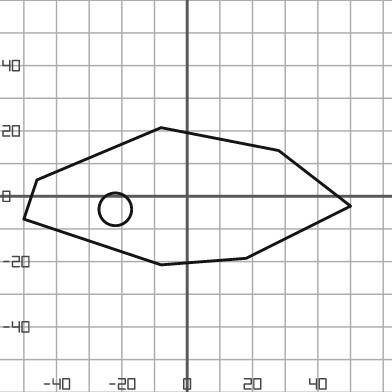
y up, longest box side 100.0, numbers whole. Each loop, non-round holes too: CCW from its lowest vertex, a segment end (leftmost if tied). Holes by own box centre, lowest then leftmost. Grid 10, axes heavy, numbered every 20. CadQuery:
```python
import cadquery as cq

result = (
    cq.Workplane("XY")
    .moveTo(-8.0, -21.0)
    .lineTo(18.0, -19.0)
    .lineTo(50.0, -3.0)
    .lineTo(28.0, 14.0)
    .lineTo(-8.0, 21.0)
    .lineTo(-46.0, 5.0)
    .lineTo(-50.0, -7.0)
    .close()
    .moveTo(-22.0, -4.0)
    .circle(5.0)
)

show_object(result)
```